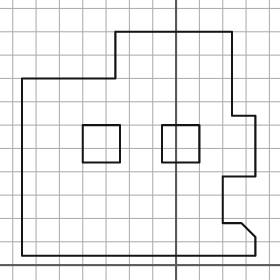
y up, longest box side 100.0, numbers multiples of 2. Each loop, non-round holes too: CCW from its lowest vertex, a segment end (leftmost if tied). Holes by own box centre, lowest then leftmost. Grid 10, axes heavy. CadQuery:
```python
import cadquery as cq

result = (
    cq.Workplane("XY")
    .moveTo(-66.0, 4.0)
    .lineTo(34.0, 4.0)
    .lineTo(34.0, 12.0)
    .lineTo(28.0, 18.0)
    .lineTo(20.0, 18.0)
    .lineTo(20.0, 38.0)
    .lineTo(34.0, 38.0)
    .lineTo(34.0, 64.0)
    .lineTo(24.0, 64.0)
    .lineTo(24.0, 100.0)
    .lineTo(-26.0, 100.0)
    .lineTo(-26.0, 80.0)
    .lineTo(-66.0, 80.0)
    .close()
    .moveTo(-40.0, 44.0)
    .lineTo(-24.0, 44.0)
    .lineTo(-24.0, 60.0)
    .lineTo(-40.0, 60.0)
    .close()
    .moveTo(-6.0, 44.0)
    .lineTo(10.0, 44.0)
    .lineTo(10.0, 60.0)
    .lineTo(-6.0, 60.0)
    .close()
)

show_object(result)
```